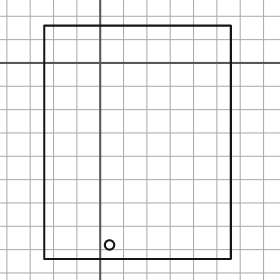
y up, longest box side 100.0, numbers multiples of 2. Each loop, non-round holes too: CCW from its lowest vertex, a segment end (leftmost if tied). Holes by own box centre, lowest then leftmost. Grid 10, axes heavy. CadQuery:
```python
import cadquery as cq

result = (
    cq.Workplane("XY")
    .moveTo(-24.0, -84.0)
    .lineTo(56.0, -84.0)
    .lineTo(56.0, 16.0)
    .lineTo(-24.0, 16.0)
    .close()
    .moveTo(4.0, -78.0)
    .circle(2.0)
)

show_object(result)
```